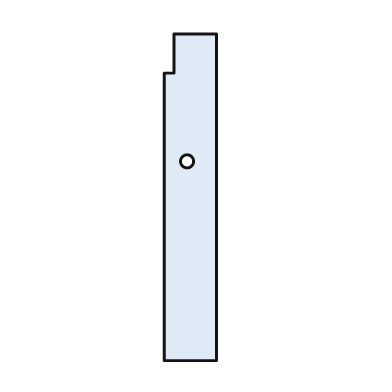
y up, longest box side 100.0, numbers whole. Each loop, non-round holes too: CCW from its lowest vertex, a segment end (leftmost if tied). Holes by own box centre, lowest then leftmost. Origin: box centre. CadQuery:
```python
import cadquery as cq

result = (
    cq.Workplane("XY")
    .moveTo(-8.0, -50.0)
    .lineTo(8.0, -50.0)
    .lineTo(8.0, 50.0)
    .lineTo(-5.0, 50.0)
    .lineTo(-5.0, 38.0)
    .lineTo(-8.0, 38.0)
    .close()
    .moveTo(-1.0, 11.0)
    .circle(2.0)
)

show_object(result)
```